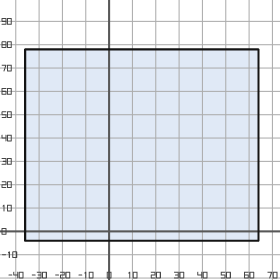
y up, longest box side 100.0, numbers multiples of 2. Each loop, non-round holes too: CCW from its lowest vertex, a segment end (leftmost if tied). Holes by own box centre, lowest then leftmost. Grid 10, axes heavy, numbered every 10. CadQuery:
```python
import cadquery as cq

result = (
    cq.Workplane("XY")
    .moveTo(-36.0, -4.0)
    .lineTo(64.0, -4.0)
    .lineTo(64.0, 78.0)
    .lineTo(-36.0, 78.0)
    .close()
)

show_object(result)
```